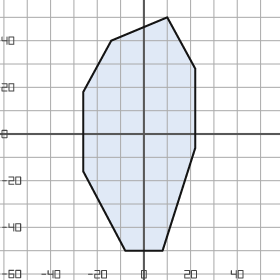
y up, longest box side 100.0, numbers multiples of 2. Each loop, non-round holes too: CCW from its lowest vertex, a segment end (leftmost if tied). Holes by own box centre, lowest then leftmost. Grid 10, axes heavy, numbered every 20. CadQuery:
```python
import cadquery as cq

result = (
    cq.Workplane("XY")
    .moveTo(-8.0, -50.0)
    .lineTo(8.0, -50.0)
    .lineTo(22.0, -6.0)
    .lineTo(22.0, 28.0)
    .lineTo(10.0, 50.0)
    .lineTo(-14.0, 40.0)
    .lineTo(-26.0, 18.0)
    .lineTo(-26.0, -16.0)
    .close()
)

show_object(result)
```